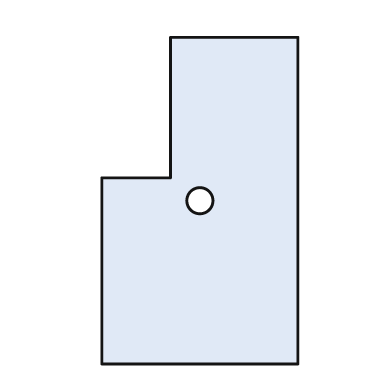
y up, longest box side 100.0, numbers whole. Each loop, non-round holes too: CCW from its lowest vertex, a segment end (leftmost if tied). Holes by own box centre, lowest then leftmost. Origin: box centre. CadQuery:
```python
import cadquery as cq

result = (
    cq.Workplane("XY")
    .moveTo(-30.0, -50.0)
    .lineTo(30.0, -50.0)
    .lineTo(30.0, 50.0)
    .lineTo(-9.0, 50.0)
    .lineTo(-9.0, 7.0)
    .lineTo(-30.0, 7.0)
    .close()
    .moveTo(0.0, 0.0)
    .circle(4.0)
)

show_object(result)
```